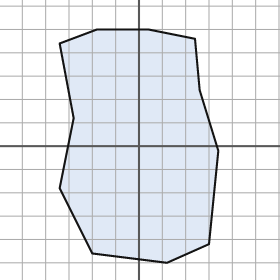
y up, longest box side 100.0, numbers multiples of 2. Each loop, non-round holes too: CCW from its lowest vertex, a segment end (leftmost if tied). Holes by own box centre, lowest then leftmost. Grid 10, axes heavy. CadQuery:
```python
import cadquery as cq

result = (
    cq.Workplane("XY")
    .moveTo(12.0, -50.0)
    .lineTo(30.0, -42.0)
    .lineTo(34.0, -2.0)
    .lineTo(26.0, 24.0)
    .lineTo(24.0, 46.0)
    .lineTo(4.0, 50.0)
    .lineTo(-18.0, 50.0)
    .lineTo(-34.0, 44.0)
    .lineTo(-28.0, 12.0)
    .lineTo(-34.0, -18.0)
    .lineTo(-20.0, -46.0)
    .close()
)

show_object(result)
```